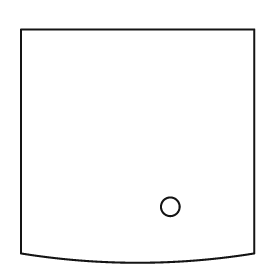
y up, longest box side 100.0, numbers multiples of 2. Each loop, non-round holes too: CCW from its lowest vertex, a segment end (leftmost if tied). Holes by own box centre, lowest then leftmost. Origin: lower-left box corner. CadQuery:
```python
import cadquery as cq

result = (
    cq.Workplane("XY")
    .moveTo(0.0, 4.0)
    .threePointArc((50.0, 0.0), (100.0, 4.0))
    .lineTo(100.0, 100.0)
    .lineTo(0.0, 100.0)
    .close()
    .moveTo(64.0, 24.0)
    .circle(4.0)
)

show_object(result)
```